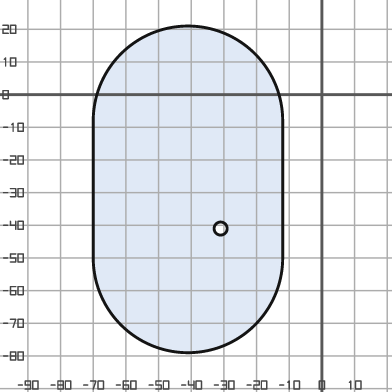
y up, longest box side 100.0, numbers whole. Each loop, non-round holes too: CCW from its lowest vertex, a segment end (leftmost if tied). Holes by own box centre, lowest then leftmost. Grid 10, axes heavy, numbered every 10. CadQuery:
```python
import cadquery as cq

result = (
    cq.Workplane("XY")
    .moveTo(-70.0, -50.0)
    .threePointArc((-41.0, -79.0), (-12.0, -50.0))
    .lineTo(-12.0, -8.0)
    .threePointArc((-41.0, 21.0), (-70.0, -8.0))
    .close()
    .moveTo(-31.0, -41.0)
    .circle(2.0)
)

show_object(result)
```